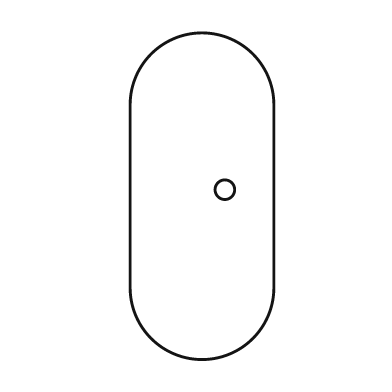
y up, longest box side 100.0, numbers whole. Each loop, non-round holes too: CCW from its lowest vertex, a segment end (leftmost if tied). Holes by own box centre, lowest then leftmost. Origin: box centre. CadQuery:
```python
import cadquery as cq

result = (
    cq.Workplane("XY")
    .moveTo(-22.0, -28.0)
    .threePointArc((0.0, -50.0), (22.0, -28.0))
    .lineTo(22.0, 28.0)
    .threePointArc((0.0, 50.0), (-22.0, 28.0))
    .close()
    .moveTo(7.0, 2.0)
    .circle(3.0)
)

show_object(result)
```